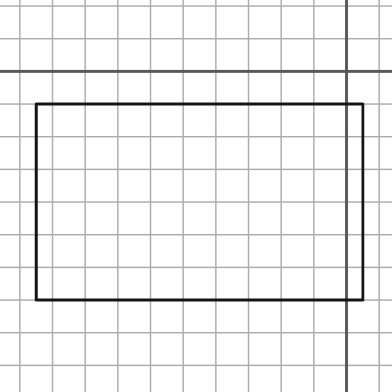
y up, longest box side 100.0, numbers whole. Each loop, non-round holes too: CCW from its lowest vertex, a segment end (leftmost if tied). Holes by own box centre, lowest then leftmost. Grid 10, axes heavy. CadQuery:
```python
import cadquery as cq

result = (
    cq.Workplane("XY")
    .moveTo(-95.0, -70.0)
    .lineTo(5.0, -70.0)
    .lineTo(5.0, -10.0)
    .lineTo(-95.0, -10.0)
    .close()
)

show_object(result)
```